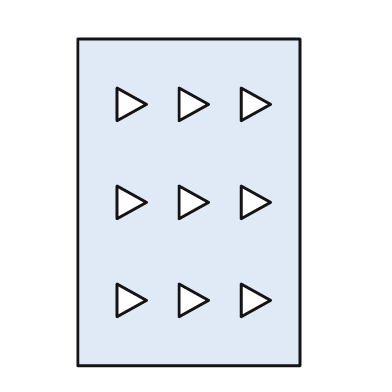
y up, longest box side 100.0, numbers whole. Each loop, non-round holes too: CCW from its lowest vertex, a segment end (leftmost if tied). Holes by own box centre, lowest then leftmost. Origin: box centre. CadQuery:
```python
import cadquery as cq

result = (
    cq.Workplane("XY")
    .moveTo(-34.0, -50.0)
    .lineTo(34.0, -50.0)
    .lineTo(34.0, 50.0)
    .lineTo(-34.0, 50.0)
    .close()
    .moveTo(-22.0, -35.0)
    .lineTo(-13.0, -30.0)
    .lineTo(-22.0, -25.0)
    .close()
    .moveTo(-3.0, -35.0)
    .lineTo(6.0, -30.0)
    .lineTo(-3.0, -25.0)
    .close()
    .moveTo(16.0, -35.0)
    .lineTo(25.0, -30.0)
    .lineTo(16.0, -25.0)
    .close()
    .moveTo(-22.0, -5.0)
    .lineTo(-13.0, 0.0)
    .lineTo(-22.0, 5.0)
    .close()
    .moveTo(-3.0, -5.0)
    .lineTo(6.0, 0.0)
    .lineTo(-3.0, 5.0)
    .close()
    .moveTo(16.0, -5.0)
    .lineTo(25.0, 0.0)
    .lineTo(16.0, 5.0)
    .close()
    .moveTo(-22.0, 25.0)
    .lineTo(-13.0, 30.0)
    .lineTo(-22.0, 35.0)
    .close()
    .moveTo(-3.0, 25.0)
    .lineTo(6.0, 30.0)
    .lineTo(-3.0, 35.0)
    .close()
    .moveTo(16.0, 25.0)
    .lineTo(25.0, 30.0)
    .lineTo(16.0, 35.0)
    .close()
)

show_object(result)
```